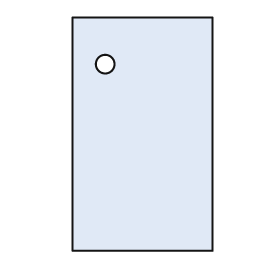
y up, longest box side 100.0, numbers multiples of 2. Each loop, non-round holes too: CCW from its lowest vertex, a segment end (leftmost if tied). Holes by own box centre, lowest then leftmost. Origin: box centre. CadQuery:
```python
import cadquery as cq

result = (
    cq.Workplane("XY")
    .moveTo(-30.0, -50.0)
    .lineTo(30.0, -50.0)
    .lineTo(30.0, 50.0)
    .lineTo(-30.0, 50.0)
    .close()
    .moveTo(-16.0, 30.0)
    .circle(4.0)
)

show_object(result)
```